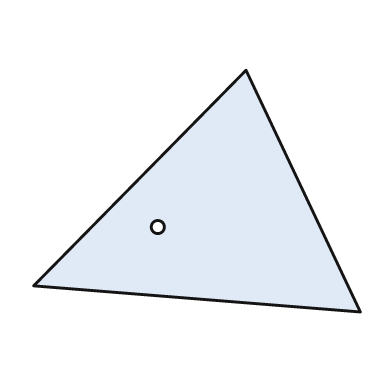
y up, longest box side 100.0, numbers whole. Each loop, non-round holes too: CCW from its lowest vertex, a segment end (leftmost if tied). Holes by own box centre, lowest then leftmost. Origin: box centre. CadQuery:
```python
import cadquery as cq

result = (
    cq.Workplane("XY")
    .moveTo(50.0, -37.0)
    .lineTo(15.0, 37.0)
    .lineTo(-50.0, -29.0)
    .close()
    .moveTo(-12.0, -11.0)
    .circle(2.0)
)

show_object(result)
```